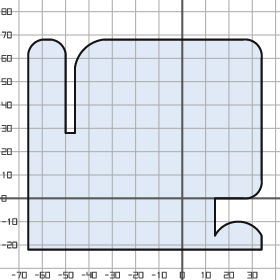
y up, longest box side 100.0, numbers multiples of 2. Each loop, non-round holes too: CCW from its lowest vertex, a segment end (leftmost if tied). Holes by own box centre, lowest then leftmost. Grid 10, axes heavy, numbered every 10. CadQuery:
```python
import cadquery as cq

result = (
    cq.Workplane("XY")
    .moveTo(-66.0, -22.0)
    .lineTo(34.0, -22.0)
    .lineTo(34.0, -16.0)
    .threePointArc((24.0, -10.0), (14.0, -16.0))
    .lineTo(14.0, 0.0)
    .lineTo(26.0, 0.0)
    .threePointArc((32.0, 2.0), (34.0, 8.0))
    .lineTo(34.0, 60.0)
    .threePointArc((32.0, 66.0), (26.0, 68.0))
    .lineTo(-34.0, 68.0)
    .threePointArc((-42.0, 64.0), (-46.0, 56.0))
    .lineTo(-46.0, 28.0)
    .lineTo(-50.0, 28.0)
    .lineTo(-50.0, 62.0)
    .threePointArc((-52.0, 66.0), (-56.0, 68.0))
    .lineTo(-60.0, 68.0)
    .threePointArc((-64.0, 66.0), (-66.0, 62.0))
    .close()
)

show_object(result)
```